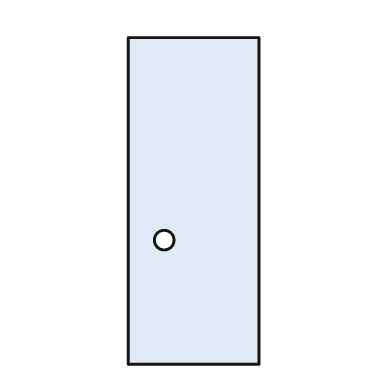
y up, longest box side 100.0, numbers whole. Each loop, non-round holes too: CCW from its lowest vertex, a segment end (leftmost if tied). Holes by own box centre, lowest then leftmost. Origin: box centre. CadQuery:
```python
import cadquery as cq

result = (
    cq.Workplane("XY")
    .moveTo(-20.0, -50.0)
    .lineTo(20.0, -50.0)
    .lineTo(20.0, 50.0)
    .lineTo(-20.0, 50.0)
    .close()
    .moveTo(-9.0, -12.0)
    .circle(3.0)
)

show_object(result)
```